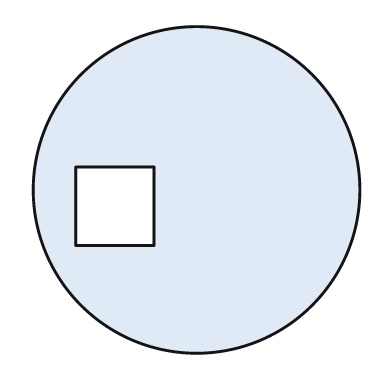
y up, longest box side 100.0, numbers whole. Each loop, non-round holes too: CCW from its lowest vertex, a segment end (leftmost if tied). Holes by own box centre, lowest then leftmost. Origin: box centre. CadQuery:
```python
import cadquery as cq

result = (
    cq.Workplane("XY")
    .moveTo(0.0, 0.0)
    .circle(50.0)
    .moveTo(-37.0, -17.0)
    .lineTo(-13.0, -17.0)
    .lineTo(-13.0, 7.0)
    .lineTo(-37.0, 7.0)
    .close()
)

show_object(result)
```